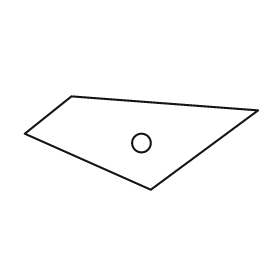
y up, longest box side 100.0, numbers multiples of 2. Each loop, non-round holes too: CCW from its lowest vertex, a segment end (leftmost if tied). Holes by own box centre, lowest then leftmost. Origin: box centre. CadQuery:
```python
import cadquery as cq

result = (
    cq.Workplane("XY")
    .moveTo(4.0, -20.0)
    .lineTo(50.0, 14.0)
    .lineTo(-30.0, 20.0)
    .lineTo(-50.0, 4.0)
    .close()
    .moveTo(0.0, 0.0)
    .circle(4.0)
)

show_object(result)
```